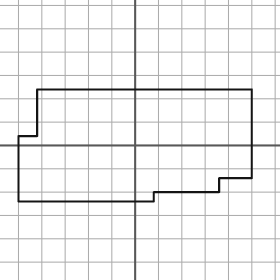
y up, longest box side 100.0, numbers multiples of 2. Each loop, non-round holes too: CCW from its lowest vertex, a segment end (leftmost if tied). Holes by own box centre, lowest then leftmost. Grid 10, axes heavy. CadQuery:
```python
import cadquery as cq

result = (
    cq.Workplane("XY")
    .moveTo(-50.0, -24.0)
    .lineTo(8.0, -24.0)
    .lineTo(8.0, -20.0)
    .lineTo(36.0, -20.0)
    .lineTo(36.0, -14.0)
    .lineTo(50.0, -14.0)
    .lineTo(50.0, 24.0)
    .lineTo(-42.0, 24.0)
    .lineTo(-42.0, 4.0)
    .lineTo(-50.0, 4.0)
    .close()
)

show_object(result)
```